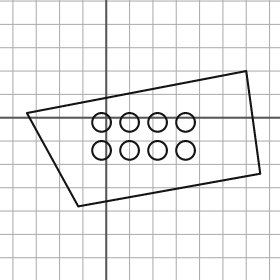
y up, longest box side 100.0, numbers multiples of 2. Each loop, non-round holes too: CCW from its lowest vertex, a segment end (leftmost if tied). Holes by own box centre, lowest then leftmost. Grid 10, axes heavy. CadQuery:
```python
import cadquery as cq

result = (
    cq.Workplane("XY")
    .moveTo(-12.0, -38.0)
    .lineTo(66.0, -24.0)
    .lineTo(60.0, 20.0)
    .lineTo(-34.0, 2.0)
    .close()
    .moveTo(-2.0, -14.0)
    .circle(4.0)
    .moveTo(10.0, -14.0)
    .circle(4.0)
    .moveTo(22.0, -14.0)
    .circle(4.0)
    .moveTo(34.0, -14.0)
    .circle(4.0)
    .moveTo(-2.0, -2.0)
    .circle(4.0)
    .moveTo(10.0, -2.0)
    .circle(4.0)
    .moveTo(22.0, -2.0)
    .circle(4.0)
    .moveTo(34.0, -2.0)
    .circle(4.0)
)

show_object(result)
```